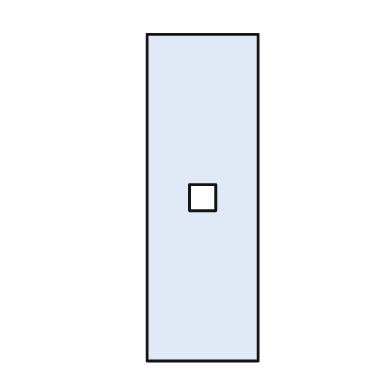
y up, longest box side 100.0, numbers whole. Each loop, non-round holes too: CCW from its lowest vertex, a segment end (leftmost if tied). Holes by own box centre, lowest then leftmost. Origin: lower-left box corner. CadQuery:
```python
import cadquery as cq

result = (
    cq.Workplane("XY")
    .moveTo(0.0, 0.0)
    .lineTo(34.0, 0.0)
    .lineTo(34.0, 100.0)
    .lineTo(0.0, 100.0)
    .close()
    .moveTo(13.0, 46.0)
    .lineTo(21.0, 46.0)
    .lineTo(21.0, 54.0)
    .lineTo(13.0, 54.0)
    .close()
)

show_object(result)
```